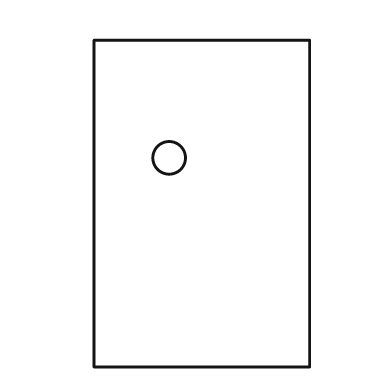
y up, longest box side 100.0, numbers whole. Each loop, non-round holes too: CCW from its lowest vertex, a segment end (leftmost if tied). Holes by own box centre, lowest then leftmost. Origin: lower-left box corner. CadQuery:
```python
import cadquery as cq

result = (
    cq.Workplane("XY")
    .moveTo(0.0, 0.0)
    .lineTo(66.0, 0.0)
    .lineTo(66.0, 100.0)
    .lineTo(0.0, 100.0)
    .close()
    .moveTo(23.0, 64.0)
    .circle(5.0)
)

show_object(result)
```